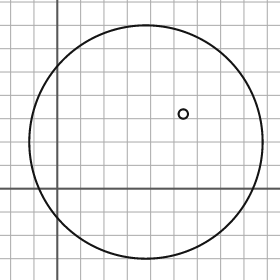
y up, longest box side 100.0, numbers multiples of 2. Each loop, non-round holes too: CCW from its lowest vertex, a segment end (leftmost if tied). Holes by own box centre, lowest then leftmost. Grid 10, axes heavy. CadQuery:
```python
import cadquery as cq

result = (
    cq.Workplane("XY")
    .moveTo(38.0, 20.0)
    .circle(50.0)
    .moveTo(54.0, 32.0)
    .circle(2.0)
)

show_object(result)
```